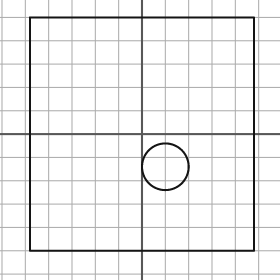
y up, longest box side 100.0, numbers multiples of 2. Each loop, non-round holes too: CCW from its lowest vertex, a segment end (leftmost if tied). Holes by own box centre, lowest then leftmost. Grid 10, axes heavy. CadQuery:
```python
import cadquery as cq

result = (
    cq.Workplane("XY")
    .moveTo(-48.0, -50.0)
    .lineTo(48.0, -50.0)
    .lineTo(48.0, 50.0)
    .lineTo(-48.0, 50.0)
    .close()
    .moveTo(10.0, -14.0)
    .circle(10.0)
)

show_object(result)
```